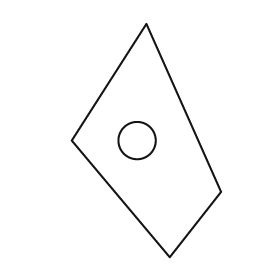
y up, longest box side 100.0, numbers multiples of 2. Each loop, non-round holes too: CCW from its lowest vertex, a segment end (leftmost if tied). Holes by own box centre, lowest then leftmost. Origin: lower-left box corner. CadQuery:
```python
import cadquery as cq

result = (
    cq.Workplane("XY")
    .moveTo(42.0, 0.0)
    .lineTo(64.0, 28.0)
    .lineTo(32.0, 100.0)
    .lineTo(0.0, 50.0)
    .close()
    .moveTo(28.0, 50.0)
    .circle(8.0)
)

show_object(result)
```